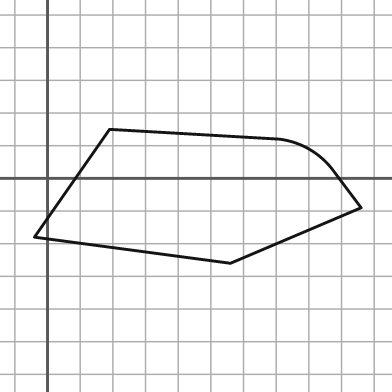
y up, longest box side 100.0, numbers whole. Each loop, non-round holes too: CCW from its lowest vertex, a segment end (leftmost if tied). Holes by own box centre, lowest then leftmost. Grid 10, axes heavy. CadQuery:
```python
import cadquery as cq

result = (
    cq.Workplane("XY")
    .moveTo(56.0, -26.0)
    .lineTo(96.0, -9.0)
    .lineTo(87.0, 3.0)
    .threePointArc((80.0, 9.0), (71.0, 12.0))
    .lineTo(19.0, 15.0)
    .lineTo(-4.0, -18.0)
    .close()
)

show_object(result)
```